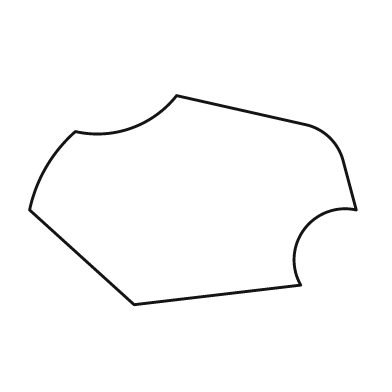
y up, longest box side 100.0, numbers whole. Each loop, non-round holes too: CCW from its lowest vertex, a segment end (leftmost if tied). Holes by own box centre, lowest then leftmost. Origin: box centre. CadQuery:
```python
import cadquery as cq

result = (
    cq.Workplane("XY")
    .moveTo(-18.0, -32.0)
    .lineTo(33.0, -26.0)
    .threePointArc((34.0, -9.0), (50.0, -3.0))
    .lineTo(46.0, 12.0)
    .threePointArc((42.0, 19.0), (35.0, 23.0))
    .lineTo(-5.0, 32.0)
    .threePointArc((-19.0, 22.0), (-36.0, 21.0))
    .threePointArc((-45.0, 10.0), (-50.0, -3.0))
    .close()
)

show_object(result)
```